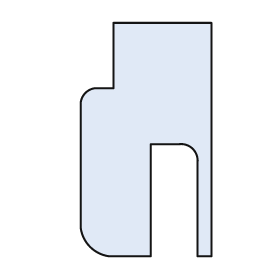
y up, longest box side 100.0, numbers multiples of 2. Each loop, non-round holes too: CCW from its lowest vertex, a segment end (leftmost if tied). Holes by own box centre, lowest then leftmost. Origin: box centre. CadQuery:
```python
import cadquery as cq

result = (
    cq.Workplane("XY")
    .moveTo(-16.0, -50.0)
    .lineTo(2.0, -50.0)
    .lineTo(2.0, -2.0)
    .lineTo(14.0, -2.0)
    .threePointArc((20.0, -4.0), (22.0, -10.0))
    .lineTo(22.0, -50.0)
    .lineTo(28.0, -50.0)
    .lineTo(28.0, 50.0)
    .lineTo(-14.0, 50.0)
    .lineTo(-14.0, 22.0)
    .lineTo(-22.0, 22.0)
    .threePointArc((-26.0, 20.0), (-28.0, 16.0))
    .lineTo(-28.0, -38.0)
    .threePointArc((-24.0, -46.0), (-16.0, -50.0))
    .close()
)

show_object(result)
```